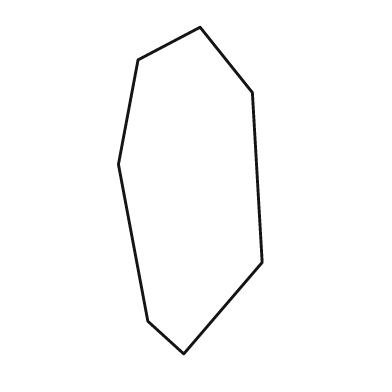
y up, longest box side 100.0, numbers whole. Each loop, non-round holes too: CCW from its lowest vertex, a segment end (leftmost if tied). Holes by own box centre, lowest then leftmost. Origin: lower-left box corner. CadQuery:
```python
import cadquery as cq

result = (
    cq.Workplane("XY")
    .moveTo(20.0, 0.0)
    .lineTo(44.0, 28.0)
    .lineTo(41.0, 80.0)
    .lineTo(25.0, 100.0)
    .lineTo(6.0, 90.0)
    .lineTo(0.0, 58.0)
    .lineTo(9.0, 10.0)
    .close()
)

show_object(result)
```